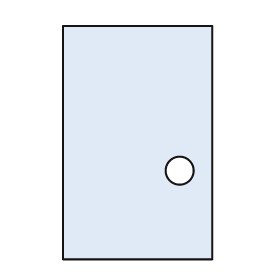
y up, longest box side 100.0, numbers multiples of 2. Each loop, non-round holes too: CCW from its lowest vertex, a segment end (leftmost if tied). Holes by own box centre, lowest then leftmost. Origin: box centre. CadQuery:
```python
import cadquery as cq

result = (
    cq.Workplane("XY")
    .moveTo(-32.0, -50.0)
    .lineTo(32.0, -50.0)
    .lineTo(32.0, 50.0)
    .lineTo(-32.0, 50.0)
    .close()
    .moveTo(18.0, -12.0)
    .circle(6.0)
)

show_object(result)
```